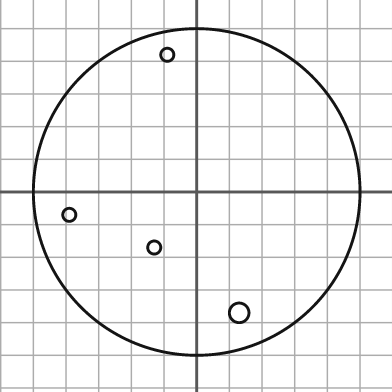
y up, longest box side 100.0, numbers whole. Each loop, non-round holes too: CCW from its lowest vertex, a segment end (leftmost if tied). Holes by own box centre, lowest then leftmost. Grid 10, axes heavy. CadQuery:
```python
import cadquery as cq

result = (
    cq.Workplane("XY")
    .moveTo(0.0, 0.0)
    .circle(50.0)
    .moveTo(13.0, -37.0)
    .circle(3.0)
    .moveTo(-13.0, -17.0)
    .circle(2.0)
    .moveTo(-39.0, -7.0)
    .circle(2.0)
    .moveTo(-9.0, 42.0)
    .circle(2.0)
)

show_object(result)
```